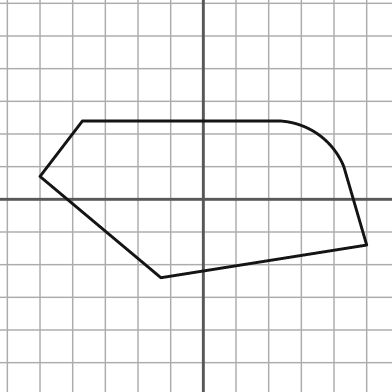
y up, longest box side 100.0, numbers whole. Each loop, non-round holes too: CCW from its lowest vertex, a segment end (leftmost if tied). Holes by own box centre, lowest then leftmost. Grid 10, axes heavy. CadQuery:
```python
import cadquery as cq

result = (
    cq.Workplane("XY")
    .moveTo(-13.0, -24.0)
    .lineTo(50.0, -14.0)
    .lineTo(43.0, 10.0)
    .threePointArc((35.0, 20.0), (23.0, 24.0))
    .lineTo(-37.0, 24.0)
    .lineTo(-50.0, 7.0)
    .close()
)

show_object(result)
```